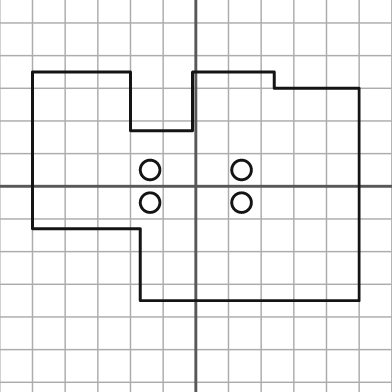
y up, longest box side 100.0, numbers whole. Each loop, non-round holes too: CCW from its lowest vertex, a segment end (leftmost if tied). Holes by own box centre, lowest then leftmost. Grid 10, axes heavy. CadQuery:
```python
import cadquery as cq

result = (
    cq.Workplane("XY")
    .moveTo(-17.0, -35.0)
    .lineTo(50.0, -35.0)
    .lineTo(50.0, 30.0)
    .lineTo(24.0, 30.0)
    .lineTo(24.0, 35.0)
    .lineTo(-1.0, 35.0)
    .lineTo(-1.0, 17.0)
    .lineTo(-20.0, 17.0)
    .lineTo(-20.0, 35.0)
    .lineTo(-50.0, 35.0)
    .lineTo(-50.0, -13.0)
    .lineTo(-17.0, -13.0)
    .close()
    .moveTo(-14.0, -5.0)
    .circle(3.0)
    .moveTo(14.0, -5.0)
    .circle(3.0)
    .moveTo(-14.0, 5.0)
    .circle(3.0)
    .moveTo(14.0, 5.0)
    .circle(3.0)
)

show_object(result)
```